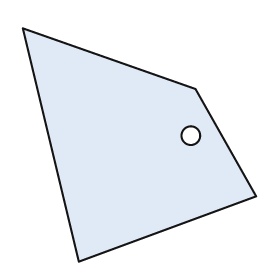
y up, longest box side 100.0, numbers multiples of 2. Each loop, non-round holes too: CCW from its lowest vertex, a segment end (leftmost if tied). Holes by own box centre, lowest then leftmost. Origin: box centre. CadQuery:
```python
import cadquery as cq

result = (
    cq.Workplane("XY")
    .moveTo(-26.0, -50.0)
    .lineTo(50.0, -22.0)
    .lineTo(24.0, 24.0)
    .lineTo(-50.0, 50.0)
    .close()
    .moveTo(22.0, 4.0)
    .circle(4.0)
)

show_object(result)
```